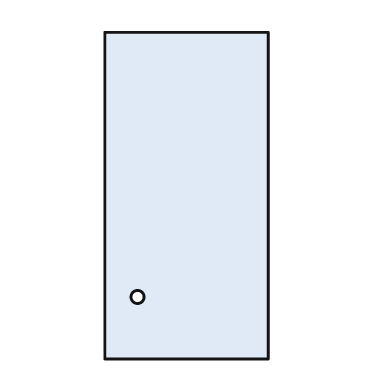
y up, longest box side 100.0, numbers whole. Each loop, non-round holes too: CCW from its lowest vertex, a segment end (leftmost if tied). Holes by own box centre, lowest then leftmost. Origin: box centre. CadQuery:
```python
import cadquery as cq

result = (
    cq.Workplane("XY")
    .moveTo(-25.0, -50.0)
    .lineTo(25.0, -50.0)
    .lineTo(25.0, 50.0)
    .lineTo(-25.0, 50.0)
    .close()
    .moveTo(-15.0, -31.0)
    .circle(2.0)
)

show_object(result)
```